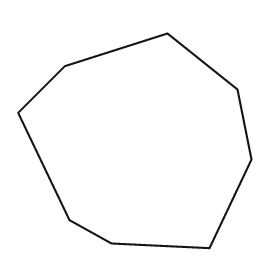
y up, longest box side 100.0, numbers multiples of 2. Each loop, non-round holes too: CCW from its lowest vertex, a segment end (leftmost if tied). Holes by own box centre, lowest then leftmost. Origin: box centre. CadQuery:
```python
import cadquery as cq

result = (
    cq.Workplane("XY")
    .moveTo(32.0, -46.0)
    .lineTo(50.0, -8.0)
    .lineTo(44.0, 22.0)
    .lineTo(14.0, 46.0)
    .lineTo(-30.0, 32.0)
    .lineTo(-50.0, 12.0)
    .lineTo(-28.0, -34.0)
    .lineTo(-10.0, -44.0)
    .close()
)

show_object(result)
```